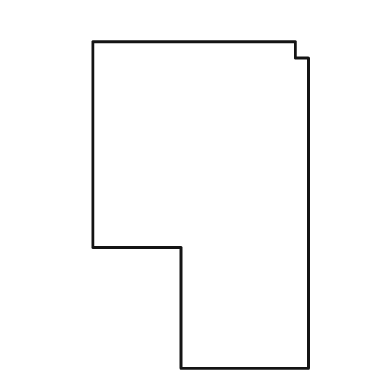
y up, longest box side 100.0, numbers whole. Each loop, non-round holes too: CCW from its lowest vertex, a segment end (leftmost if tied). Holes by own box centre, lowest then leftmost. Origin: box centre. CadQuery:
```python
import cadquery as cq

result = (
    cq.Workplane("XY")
    .moveTo(-6.0, -50.0)
    .lineTo(33.0, -50.0)
    .lineTo(33.0, 45.0)
    .lineTo(29.0, 45.0)
    .lineTo(29.0, 50.0)
    .lineTo(-33.0, 50.0)
    .lineTo(-33.0, -13.0)
    .lineTo(-6.0, -13.0)
    .close()
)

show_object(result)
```